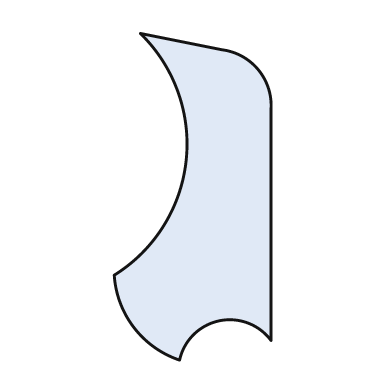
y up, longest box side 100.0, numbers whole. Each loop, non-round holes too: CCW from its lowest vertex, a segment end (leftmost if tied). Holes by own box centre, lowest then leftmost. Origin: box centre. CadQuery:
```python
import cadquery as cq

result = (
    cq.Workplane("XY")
    .moveTo(-4.0, -50.0)
    .threePointArc((8.0, -38.0), (24.0, -44.0))
    .lineTo(24.0, 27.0)
    .threePointArc((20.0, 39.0), (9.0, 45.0))
    .lineTo(-16.0, 50.0)
    .threePointArc((-2.0, 11.0), (-24.0, -24.0))
    .threePointArc((-18.0, -40.0), (-4.0, -50.0))
    .close()
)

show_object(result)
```